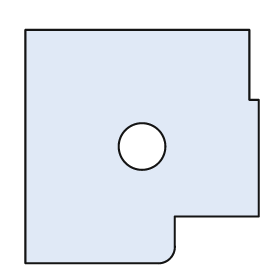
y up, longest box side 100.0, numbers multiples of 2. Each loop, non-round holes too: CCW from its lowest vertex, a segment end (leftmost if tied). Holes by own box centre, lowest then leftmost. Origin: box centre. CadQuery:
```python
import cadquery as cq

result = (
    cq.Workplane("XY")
    .moveTo(-50.0, -50.0)
    .lineTo(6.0, -50.0)
    .threePointArc((12.0, -48.0), (14.0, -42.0))
    .lineTo(14.0, -30.0)
    .lineTo(50.0, -30.0)
    .lineTo(50.0, 20.0)
    .lineTo(46.0, 20.0)
    .lineTo(46.0, 50.0)
    .lineTo(-50.0, 50.0)
    .close()
    .moveTo(0.0, 0.0)
    .circle(10.0)
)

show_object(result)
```